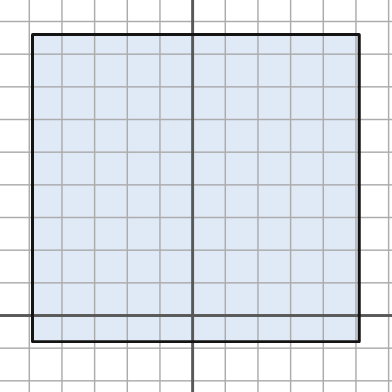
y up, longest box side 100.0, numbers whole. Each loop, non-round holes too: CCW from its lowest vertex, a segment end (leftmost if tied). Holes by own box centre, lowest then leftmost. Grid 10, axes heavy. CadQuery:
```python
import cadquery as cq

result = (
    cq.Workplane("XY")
    .moveTo(-49.0, -8.0)
    .lineTo(51.0, -8.0)
    .lineTo(51.0, 86.0)
    .lineTo(-49.0, 86.0)
    .close()
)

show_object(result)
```